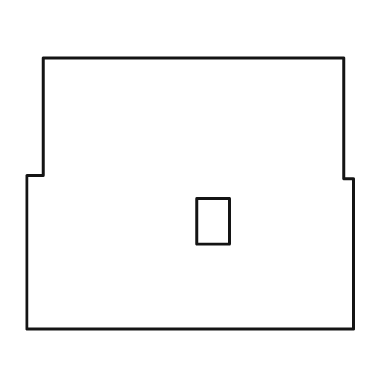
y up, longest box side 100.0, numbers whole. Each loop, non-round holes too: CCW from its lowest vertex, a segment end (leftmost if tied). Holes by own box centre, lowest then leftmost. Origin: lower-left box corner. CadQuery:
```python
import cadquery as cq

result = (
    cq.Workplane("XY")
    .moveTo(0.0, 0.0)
    .lineTo(100.0, 0.0)
    .lineTo(100.0, 46.0)
    .lineTo(97.0, 46.0)
    .lineTo(97.0, 83.0)
    .lineTo(5.0, 83.0)
    .lineTo(5.0, 47.0)
    .lineTo(0.0, 47.0)
    .close()
    .moveTo(52.0, 26.0)
    .lineTo(62.0, 26.0)
    .lineTo(62.0, 40.0)
    .lineTo(52.0, 40.0)
    .close()
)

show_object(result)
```